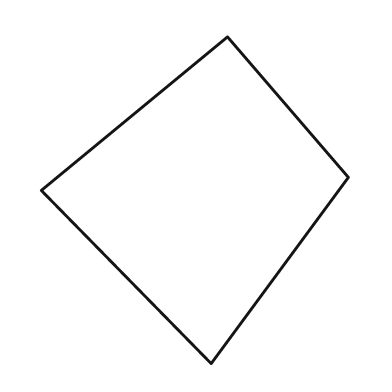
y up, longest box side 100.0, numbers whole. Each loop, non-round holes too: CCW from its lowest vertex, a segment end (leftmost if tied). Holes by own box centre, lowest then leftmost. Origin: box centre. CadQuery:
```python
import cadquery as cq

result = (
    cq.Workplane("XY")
    .moveTo(5.0, -50.0)
    .lineTo(47.0, 7.0)
    .lineTo(10.0, 50.0)
    .lineTo(-47.0, 3.0)
    .close()
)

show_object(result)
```